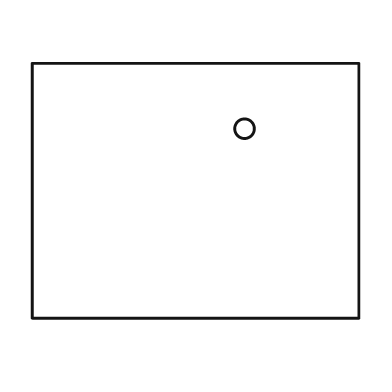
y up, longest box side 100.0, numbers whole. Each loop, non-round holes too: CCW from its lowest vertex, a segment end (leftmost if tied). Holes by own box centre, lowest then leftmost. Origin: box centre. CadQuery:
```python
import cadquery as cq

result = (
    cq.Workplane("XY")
    .moveTo(-50.0, -39.0)
    .lineTo(50.0, -39.0)
    .lineTo(50.0, 39.0)
    .lineTo(-50.0, 39.0)
    .close()
    .moveTo(15.0, 19.0)
    .circle(3.0)
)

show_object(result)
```